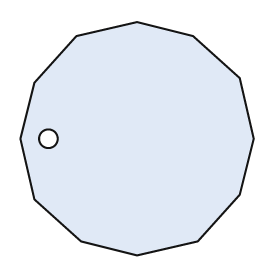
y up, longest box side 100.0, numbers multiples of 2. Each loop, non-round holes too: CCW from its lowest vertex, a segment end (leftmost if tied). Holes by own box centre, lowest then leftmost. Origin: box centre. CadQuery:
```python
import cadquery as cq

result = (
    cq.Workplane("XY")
    .moveTo(0.0, -50.0)
    .lineTo(26.0, -44.0)
    .lineTo(44.0, -24.0)
    .lineTo(50.0, 0.0)
    .lineTo(44.0, 26.0)
    .lineTo(24.0, 44.0)
    .lineTo(0.0, 50.0)
    .lineTo(-26.0, 44.0)
    .lineTo(-44.0, 24.0)
    .lineTo(-50.0, 0.0)
    .lineTo(-44.0, -26.0)
    .lineTo(-24.0, -44.0)
    .close()
    .moveTo(-38.0, 0.0)
    .circle(4.0)
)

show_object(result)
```